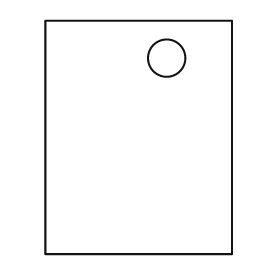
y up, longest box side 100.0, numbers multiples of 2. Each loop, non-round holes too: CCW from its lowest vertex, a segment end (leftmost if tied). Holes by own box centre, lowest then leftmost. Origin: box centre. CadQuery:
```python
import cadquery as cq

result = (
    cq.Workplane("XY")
    .moveTo(-40.0, -50.0)
    .lineTo(40.0, -50.0)
    .lineTo(40.0, 50.0)
    .lineTo(-40.0, 50.0)
    .close()
    .moveTo(12.0, 34.0)
    .circle(8.0)
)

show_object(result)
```